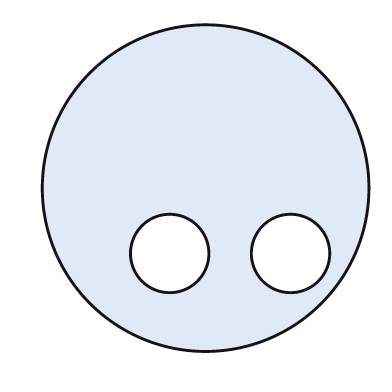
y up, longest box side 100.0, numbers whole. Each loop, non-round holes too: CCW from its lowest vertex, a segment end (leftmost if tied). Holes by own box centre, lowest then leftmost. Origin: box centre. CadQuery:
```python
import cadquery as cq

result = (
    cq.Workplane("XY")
    .moveTo(0.0, 0.0)
    .circle(50.0)
    .moveTo(-11.0, -20.0)
    .circle(12.0)
    .moveTo(26.0, -20.0)
    .circle(12.0)
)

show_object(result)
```